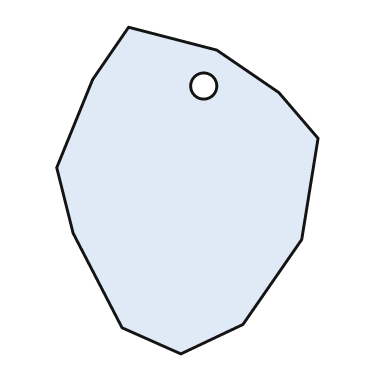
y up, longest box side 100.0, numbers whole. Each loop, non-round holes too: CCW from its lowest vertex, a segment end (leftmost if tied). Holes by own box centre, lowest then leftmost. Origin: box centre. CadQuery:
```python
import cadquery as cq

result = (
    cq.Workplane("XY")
    .moveTo(-2.0, -50.0)
    .lineTo(17.0, -41.0)
    .lineTo(35.0, -15.0)
    .lineTo(40.0, 16.0)
    .lineTo(28.0, 30.0)
    .lineTo(9.0, 43.0)
    .lineTo(-18.0, 50.0)
    .lineTo(-29.0, 34.0)
    .lineTo(-40.0, 7.0)
    .lineTo(-35.0, -13.0)
    .lineTo(-20.0, -42.0)
    .close()
    .moveTo(5.0, 32.0)
    .circle(4.0)
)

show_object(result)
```